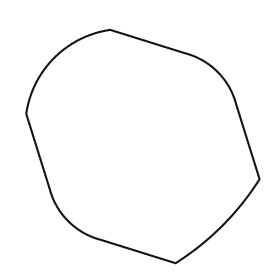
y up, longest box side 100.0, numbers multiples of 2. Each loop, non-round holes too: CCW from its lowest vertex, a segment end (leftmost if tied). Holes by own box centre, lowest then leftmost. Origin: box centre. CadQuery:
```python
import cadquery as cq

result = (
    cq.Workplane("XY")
    .moveTo(14.0, -50.0)
    .threePointArc((34.0, -34.0), (50.0, -14.0))
    .lineTo(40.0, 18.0)
    .threePointArc((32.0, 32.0), (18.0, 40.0))
    .lineTo(-14.0, 50.0)
    .threePointArc((-38.0, 38.0), (-50.0, 14.0))
    .lineTo(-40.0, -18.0)
    .threePointArc((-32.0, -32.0), (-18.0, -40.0))
    .close()
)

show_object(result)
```